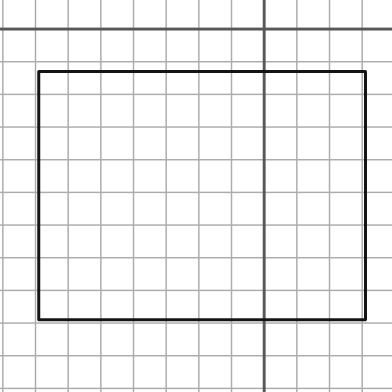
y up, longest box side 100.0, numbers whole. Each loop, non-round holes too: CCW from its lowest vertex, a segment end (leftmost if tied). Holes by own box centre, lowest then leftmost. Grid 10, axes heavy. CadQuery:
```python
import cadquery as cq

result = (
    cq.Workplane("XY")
    .moveTo(-69.0, -89.0)
    .lineTo(31.0, -89.0)
    .lineTo(31.0, -13.0)
    .lineTo(-69.0, -13.0)
    .close()
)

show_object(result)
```